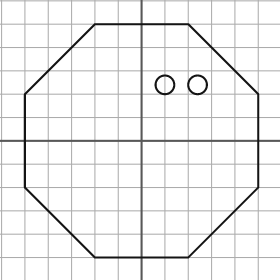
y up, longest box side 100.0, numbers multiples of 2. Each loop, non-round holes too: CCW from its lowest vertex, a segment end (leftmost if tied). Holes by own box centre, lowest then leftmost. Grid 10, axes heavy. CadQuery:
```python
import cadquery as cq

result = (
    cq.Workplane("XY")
    .moveTo(-20.0, -50.0)
    .lineTo(20.0, -50.0)
    .lineTo(50.0, -20.0)
    .lineTo(50.0, 20.0)
    .lineTo(20.0, 50.0)
    .lineTo(-20.0, 50.0)
    .lineTo(-50.0, 20.0)
    .lineTo(-50.0, -20.0)
    .close()
    .moveTo(10.0, 24.0)
    .circle(4.0)
    .moveTo(24.0, 24.0)
    .circle(4.0)
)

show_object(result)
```